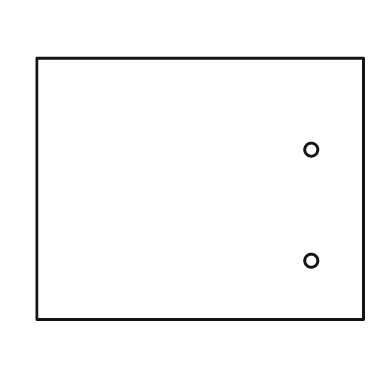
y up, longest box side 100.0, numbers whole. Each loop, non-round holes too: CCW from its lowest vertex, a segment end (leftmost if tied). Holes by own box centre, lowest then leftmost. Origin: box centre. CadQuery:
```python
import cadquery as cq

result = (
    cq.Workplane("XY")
    .moveTo(-50.0, -40.0)
    .lineTo(50.0, -40.0)
    .lineTo(50.0, 40.0)
    .lineTo(-50.0, 40.0)
    .close()
    .moveTo(34.0, -22.0)
    .circle(2.0)
    .moveTo(34.0, 12.0)
    .circle(2.0)
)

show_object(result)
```